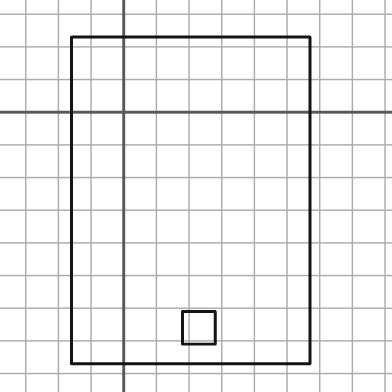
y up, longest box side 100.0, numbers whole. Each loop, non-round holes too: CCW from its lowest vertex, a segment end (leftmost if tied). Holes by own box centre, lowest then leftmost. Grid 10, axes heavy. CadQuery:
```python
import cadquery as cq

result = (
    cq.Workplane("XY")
    .moveTo(-16.0, -77.0)
    .lineTo(57.0, -77.0)
    .lineTo(57.0, 23.0)
    .lineTo(-16.0, 23.0)
    .close()
    .moveTo(18.0, -71.0)
    .lineTo(28.0, -71.0)
    .lineTo(28.0, -61.0)
    .lineTo(18.0, -61.0)
    .close()
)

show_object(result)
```